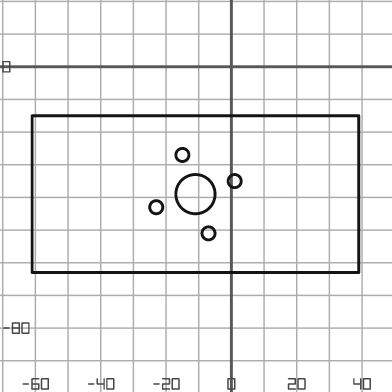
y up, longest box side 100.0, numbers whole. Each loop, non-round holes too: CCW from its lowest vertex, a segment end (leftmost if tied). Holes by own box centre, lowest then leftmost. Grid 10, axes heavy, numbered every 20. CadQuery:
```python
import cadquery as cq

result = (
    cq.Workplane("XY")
    .moveTo(-61.0, -63.0)
    .lineTo(39.0, -63.0)
    .lineTo(39.0, -15.0)
    .lineTo(-61.0, -15.0)
    .close()
    .moveTo(-7.0, -51.0)
    .circle(2.0)
    .moveTo(-23.0, -43.0)
    .circle(2.0)
    .moveTo(-11.0, -39.0)
    .circle(6.0)
    .moveTo(1.0, -35.0)
    .circle(2.0)
    .moveTo(-15.0, -27.0)
    .circle(2.0)
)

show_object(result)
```